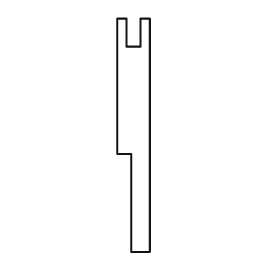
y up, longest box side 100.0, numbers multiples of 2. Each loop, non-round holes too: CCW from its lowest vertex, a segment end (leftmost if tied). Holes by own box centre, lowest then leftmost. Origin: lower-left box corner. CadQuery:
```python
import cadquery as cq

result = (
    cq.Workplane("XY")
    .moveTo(6.0, 0.0)
    .lineTo(14.0, 0.0)
    .lineTo(14.0, 100.0)
    .lineTo(10.0, 100.0)
    .lineTo(10.0, 88.0)
    .lineTo(4.0, 88.0)
    .lineTo(4.0, 100.0)
    .lineTo(0.0, 100.0)
    .lineTo(0.0, 42.0)
    .lineTo(6.0, 42.0)
    .close()
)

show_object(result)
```